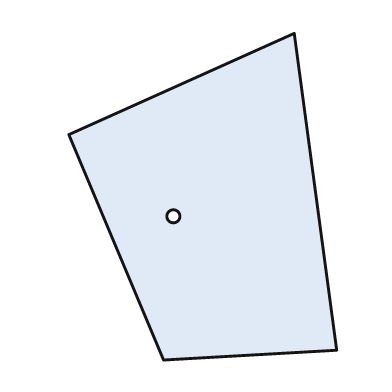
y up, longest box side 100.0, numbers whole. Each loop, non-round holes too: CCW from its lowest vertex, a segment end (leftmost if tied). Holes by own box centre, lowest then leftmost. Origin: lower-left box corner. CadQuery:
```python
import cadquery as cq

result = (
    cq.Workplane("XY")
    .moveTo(29.0, 0.0)
    .lineTo(82.0, 3.0)
    .lineTo(69.0, 100.0)
    .lineTo(0.0, 69.0)
    .close()
    .moveTo(32.0, 44.0)
    .circle(2.0)
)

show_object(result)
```